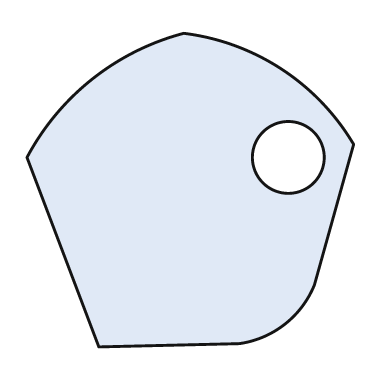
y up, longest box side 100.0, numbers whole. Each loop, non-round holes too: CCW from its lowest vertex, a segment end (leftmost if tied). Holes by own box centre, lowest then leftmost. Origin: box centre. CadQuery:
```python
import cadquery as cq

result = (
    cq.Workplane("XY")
    .moveTo(-28.0, -48.0)
    .lineTo(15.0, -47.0)
    .threePointArc((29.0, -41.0), (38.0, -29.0))
    .lineTo(50.0, 14.0)
    .threePointArc((28.0, 37.0), (-2.0, 48.0))
    .threePointArc((-30.0, 34.0), (-50.0, 10.0))
    .close()
    .moveTo(30.0, 10.0)
    .circle(11.0)
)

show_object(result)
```